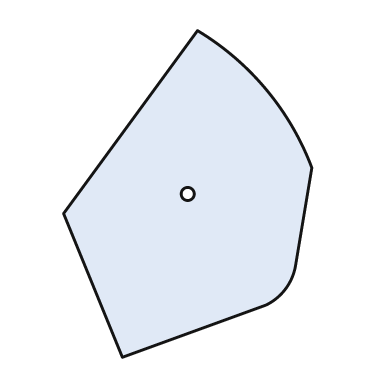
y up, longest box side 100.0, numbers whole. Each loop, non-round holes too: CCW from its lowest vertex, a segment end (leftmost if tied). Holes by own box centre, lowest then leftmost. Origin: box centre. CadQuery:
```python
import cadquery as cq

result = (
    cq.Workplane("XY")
    .moveTo(-20.0, -50.0)
    .lineTo(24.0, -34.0)
    .threePointArc((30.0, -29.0), (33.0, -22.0))
    .lineTo(38.0, 8.0)
    .threePointArc((24.0, 32.0), (3.0, 50.0))
    .lineTo(-38.0, -6.0)
    .close()
    .moveTo(0.0, 0.0)
    .circle(2.0)
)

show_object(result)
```